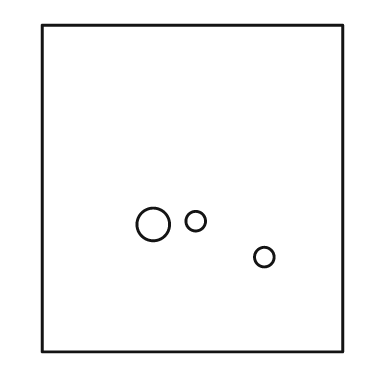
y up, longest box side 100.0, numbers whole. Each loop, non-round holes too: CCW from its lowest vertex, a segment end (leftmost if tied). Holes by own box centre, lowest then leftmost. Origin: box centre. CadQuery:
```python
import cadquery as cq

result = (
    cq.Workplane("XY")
    .moveTo(-46.0, -50.0)
    .lineTo(46.0, -50.0)
    .lineTo(46.0, 50.0)
    .lineTo(-46.0, 50.0)
    .close()
    .moveTo(22.0, -21.0)
    .circle(3.0)
    .moveTo(-12.0, -11.0)
    .circle(5.0)
    .moveTo(1.0, -10.0)
    .circle(3.0)
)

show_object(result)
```